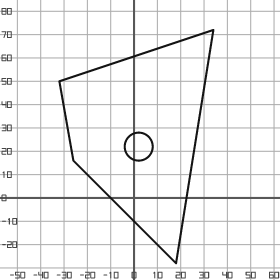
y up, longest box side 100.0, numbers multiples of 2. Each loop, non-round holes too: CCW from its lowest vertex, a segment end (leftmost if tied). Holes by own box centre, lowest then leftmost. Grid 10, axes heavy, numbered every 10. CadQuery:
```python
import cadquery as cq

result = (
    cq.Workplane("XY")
    .moveTo(18.0, -28.0)
    .lineTo(34.0, 72.0)
    .lineTo(-32.0, 50.0)
    .lineTo(-26.0, 16.0)
    .close()
    .moveTo(2.0, 22.0)
    .circle(6.0)
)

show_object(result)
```